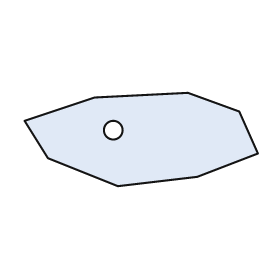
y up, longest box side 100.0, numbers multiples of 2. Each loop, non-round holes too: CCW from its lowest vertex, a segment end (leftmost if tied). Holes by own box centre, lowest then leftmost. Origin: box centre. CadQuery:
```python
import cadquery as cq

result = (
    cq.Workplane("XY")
    .moveTo(-10.0, -20.0)
    .lineTo(24.0, -16.0)
    .lineTo(50.0, -6.0)
    .lineTo(42.0, 12.0)
    .lineTo(20.0, 20.0)
    .lineTo(-20.0, 18.0)
    .lineTo(-50.0, 8.0)
    .lineTo(-40.0, -8.0)
    .close()
    .moveTo(-12.0, 4.0)
    .circle(4.0)
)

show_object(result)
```